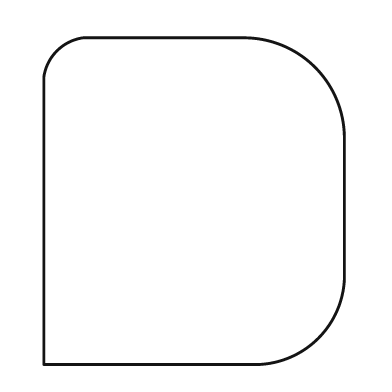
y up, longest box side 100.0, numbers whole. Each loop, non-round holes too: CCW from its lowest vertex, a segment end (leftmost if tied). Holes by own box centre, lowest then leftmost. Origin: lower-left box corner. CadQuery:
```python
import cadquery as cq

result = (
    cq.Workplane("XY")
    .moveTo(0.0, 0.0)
    .lineTo(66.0, 0.0)
    .threePointArc((84.0, 8.0), (92.0, 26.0))
    .lineTo(92.0, 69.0)
    .threePointArc((83.0, 91.0), (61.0, 100.0))
    .lineTo(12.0, 100.0)
    .threePointArc((4.0, 96.0), (0.0, 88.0))
    .close()
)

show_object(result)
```